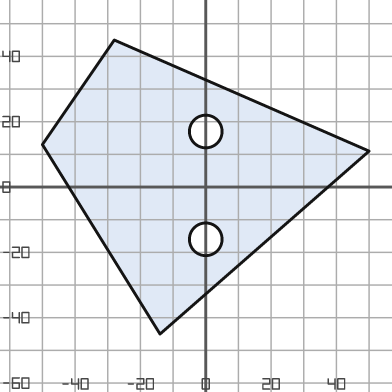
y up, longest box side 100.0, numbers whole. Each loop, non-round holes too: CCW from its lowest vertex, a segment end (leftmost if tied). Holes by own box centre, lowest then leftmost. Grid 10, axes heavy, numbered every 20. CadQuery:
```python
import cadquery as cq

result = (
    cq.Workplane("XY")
    .moveTo(-14.0, -45.0)
    .lineTo(50.0, 11.0)
    .lineTo(-28.0, 45.0)
    .lineTo(-50.0, 13.0)
    .close()
    .moveTo(0.0, -16.0)
    .circle(5.0)
    .moveTo(0.0, 17.0)
    .circle(5.0)
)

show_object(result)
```